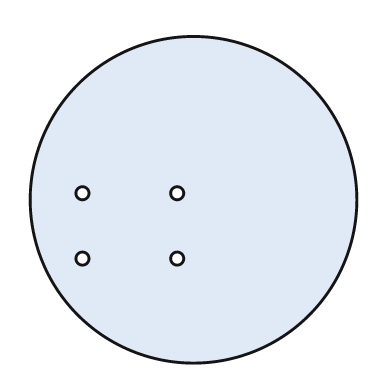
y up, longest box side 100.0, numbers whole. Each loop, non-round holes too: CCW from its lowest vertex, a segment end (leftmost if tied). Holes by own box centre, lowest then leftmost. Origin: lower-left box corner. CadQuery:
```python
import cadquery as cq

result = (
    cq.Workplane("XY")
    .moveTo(50.0, 50.0)
    .circle(50.0)
    .moveTo(16.0, 32.0)
    .circle(2.0)
    .moveTo(45.0, 32.0)
    .circle(2.0)
    .moveTo(16.0, 52.0)
    .circle(2.0)
    .moveTo(45.0, 52.0)
    .circle(2.0)
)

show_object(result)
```